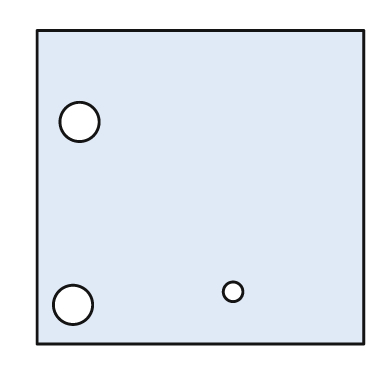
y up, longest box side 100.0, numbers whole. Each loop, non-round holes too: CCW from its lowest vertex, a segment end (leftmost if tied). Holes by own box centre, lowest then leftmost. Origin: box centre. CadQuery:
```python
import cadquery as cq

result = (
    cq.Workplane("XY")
    .moveTo(-50.0, -48.0)
    .lineTo(50.0, -48.0)
    .lineTo(50.0, 48.0)
    .lineTo(-50.0, 48.0)
    .close()
    .moveTo(-39.0, -36.0)
    .circle(6.0)
    .moveTo(10.0, -32.0)
    .circle(3.0)
    .moveTo(-37.0, 20.0)
    .circle(6.0)
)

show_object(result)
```